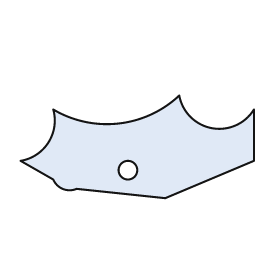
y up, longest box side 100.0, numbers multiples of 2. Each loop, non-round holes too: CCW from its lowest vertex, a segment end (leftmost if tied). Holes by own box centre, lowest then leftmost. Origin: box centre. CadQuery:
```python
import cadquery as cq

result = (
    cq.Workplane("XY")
    .moveTo(12.0, -22.0)
    .lineTo(50.0, -6.0)
    .lineTo(50.0, 16.0)
    .threePointArc((32.0, 8.0), (18.0, 22.0))
    .threePointArc((-8.0, 10.0), (-36.0, 16.0))
    .threePointArc((-38.0, 2.0), (-50.0, -6.0))
    .lineTo(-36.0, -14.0)
    .threePointArc((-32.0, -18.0), (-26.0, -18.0))
    .close()
    .moveTo(-4.0, -10.0)
    .circle(4.0)
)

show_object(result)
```